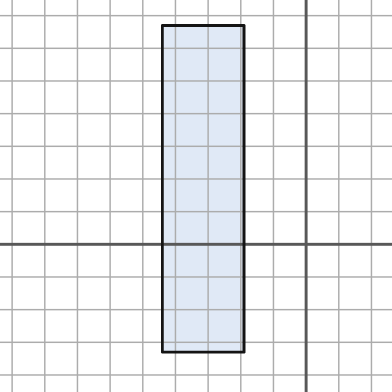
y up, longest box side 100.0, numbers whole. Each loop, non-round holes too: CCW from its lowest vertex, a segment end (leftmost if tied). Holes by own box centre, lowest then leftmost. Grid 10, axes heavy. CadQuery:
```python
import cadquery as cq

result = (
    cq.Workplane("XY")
    .moveTo(-44.0, -33.0)
    .lineTo(-19.0, -33.0)
    .lineTo(-19.0, 67.0)
    .lineTo(-44.0, 67.0)
    .close()
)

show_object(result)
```